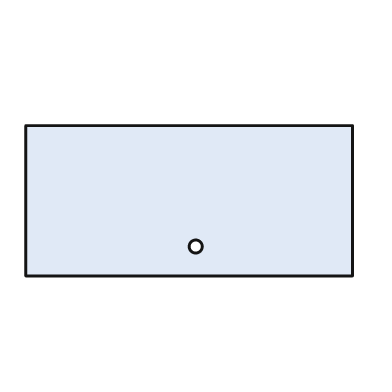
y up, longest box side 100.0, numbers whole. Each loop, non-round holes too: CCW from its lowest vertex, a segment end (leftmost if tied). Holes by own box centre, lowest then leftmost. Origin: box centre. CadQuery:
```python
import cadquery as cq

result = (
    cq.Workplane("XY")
    .moveTo(-50.0, -23.0)
    .lineTo(50.0, -23.0)
    .lineTo(50.0, 23.0)
    .lineTo(-50.0, 23.0)
    .close()
    .moveTo(2.0, -14.0)
    .circle(2.0)
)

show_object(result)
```